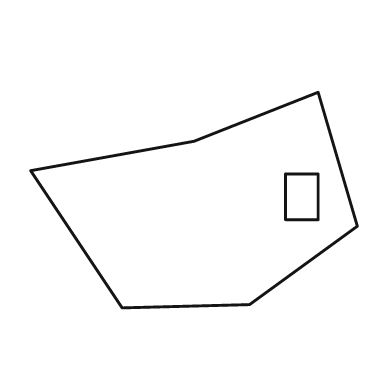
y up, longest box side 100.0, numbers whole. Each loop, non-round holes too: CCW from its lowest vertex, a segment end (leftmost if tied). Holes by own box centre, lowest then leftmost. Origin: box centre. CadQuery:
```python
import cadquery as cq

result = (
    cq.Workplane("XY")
    .moveTo(-22.0, -33.0)
    .lineTo(17.0, -32.0)
    .lineTo(50.0, -8.0)
    .lineTo(38.0, 33.0)
    .lineTo(0.0, 18.0)
    .lineTo(-50.0, 9.0)
    .close()
    .moveTo(28.0, -6.0)
    .lineTo(38.0, -6.0)
    .lineTo(38.0, 8.0)
    .lineTo(28.0, 8.0)
    .close()
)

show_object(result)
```